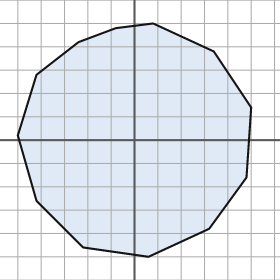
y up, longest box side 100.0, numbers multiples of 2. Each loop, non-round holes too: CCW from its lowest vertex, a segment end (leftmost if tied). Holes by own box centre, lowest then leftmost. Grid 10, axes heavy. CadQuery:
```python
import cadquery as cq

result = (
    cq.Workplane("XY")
    .moveTo(6.0, -50.0)
    .lineTo(32.0, -38.0)
    .lineTo(48.0, -16.0)
    .lineTo(50.0, 14.0)
    .lineTo(34.0, 38.0)
    .lineTo(8.0, 50.0)
    .lineTo(-8.0, 48.0)
    .lineTo(-24.0, 42.0)
    .lineTo(-42.0, 28.0)
    .lineTo(-50.0, 2.0)
    .lineTo(-42.0, -26.0)
    .lineTo(-22.0, -46.0)
    .close()
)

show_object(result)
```